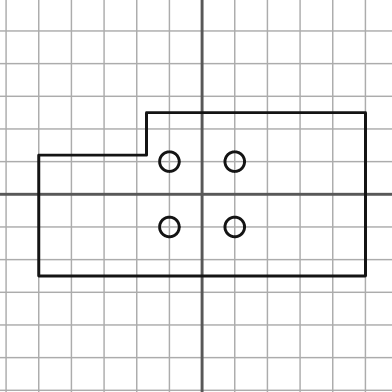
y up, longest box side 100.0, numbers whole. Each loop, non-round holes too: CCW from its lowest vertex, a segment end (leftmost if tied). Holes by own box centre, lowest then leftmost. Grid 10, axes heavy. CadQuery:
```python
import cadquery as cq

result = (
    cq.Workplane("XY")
    .moveTo(-50.0, -25.0)
    .lineTo(50.0, -25.0)
    .lineTo(50.0, 25.0)
    .lineTo(-17.0, 25.0)
    .lineTo(-17.0, 12.0)
    .lineTo(-50.0, 12.0)
    .close()
    .moveTo(-10.0, -10.0)
    .circle(3.0)
    .moveTo(10.0, -10.0)
    .circle(3.0)
    .moveTo(-10.0, 10.0)
    .circle(3.0)
    .moveTo(10.0, 10.0)
    .circle(3.0)
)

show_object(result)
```